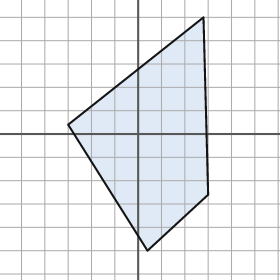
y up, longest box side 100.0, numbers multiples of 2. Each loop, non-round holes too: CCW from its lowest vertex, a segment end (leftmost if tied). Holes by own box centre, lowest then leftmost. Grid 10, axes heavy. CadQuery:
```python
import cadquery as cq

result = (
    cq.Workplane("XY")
    .moveTo(4.0, -50.0)
    .lineTo(30.0, -26.0)
    .lineTo(28.0, 50.0)
    .lineTo(-30.0, 4.0)
    .close()
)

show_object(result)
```